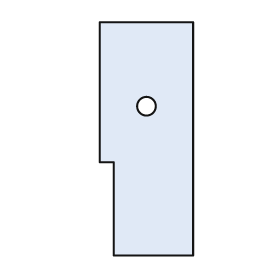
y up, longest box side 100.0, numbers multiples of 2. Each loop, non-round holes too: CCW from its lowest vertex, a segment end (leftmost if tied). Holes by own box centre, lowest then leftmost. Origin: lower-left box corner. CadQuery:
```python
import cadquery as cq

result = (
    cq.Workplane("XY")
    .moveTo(6.0, 0.0)
    .lineTo(40.0, 0.0)
    .lineTo(40.0, 100.0)
    .lineTo(0.0, 100.0)
    .lineTo(0.0, 40.0)
    .lineTo(6.0, 40.0)
    .close()
    .moveTo(20.0, 64.0)
    .circle(4.0)
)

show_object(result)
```